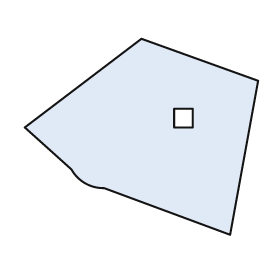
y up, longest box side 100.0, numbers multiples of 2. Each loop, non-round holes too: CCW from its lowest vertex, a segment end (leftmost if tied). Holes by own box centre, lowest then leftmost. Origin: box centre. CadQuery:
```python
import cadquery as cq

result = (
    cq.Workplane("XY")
    .moveTo(38.0, -42.0)
    .lineTo(50.0, 24.0)
    .lineTo(0.0, 42.0)
    .lineTo(-50.0, 4.0)
    .lineTo(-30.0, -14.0)
    .threePointArc((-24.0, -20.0), (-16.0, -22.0))
    .close()
    .moveTo(14.0, 4.0)
    .lineTo(22.0, 4.0)
    .lineTo(22.0, 12.0)
    .lineTo(14.0, 12.0)
    .close()
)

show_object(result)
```